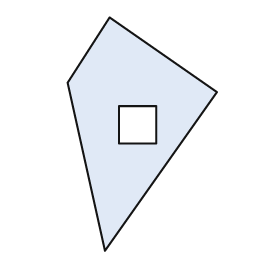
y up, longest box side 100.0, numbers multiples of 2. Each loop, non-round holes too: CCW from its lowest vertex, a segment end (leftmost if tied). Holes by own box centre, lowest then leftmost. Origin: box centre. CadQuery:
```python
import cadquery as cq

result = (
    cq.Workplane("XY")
    .moveTo(-16.0, -50.0)
    .lineTo(32.0, 18.0)
    .lineTo(-14.0, 50.0)
    .lineTo(-32.0, 22.0)
    .close()
    .moveTo(-10.0, -4.0)
    .lineTo(6.0, -4.0)
    .lineTo(6.0, 12.0)
    .lineTo(-10.0, 12.0)
    .close()
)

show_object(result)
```